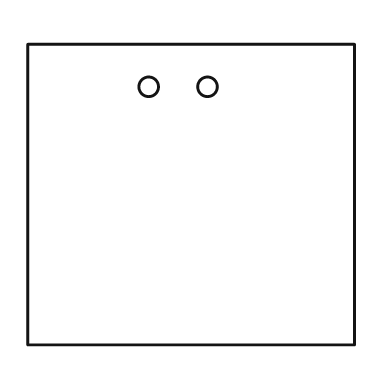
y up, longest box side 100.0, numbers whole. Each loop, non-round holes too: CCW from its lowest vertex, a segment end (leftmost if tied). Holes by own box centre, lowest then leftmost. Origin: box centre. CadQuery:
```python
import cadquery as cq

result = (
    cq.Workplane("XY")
    .moveTo(-50.0, -46.0)
    .lineTo(50.0, -46.0)
    .lineTo(50.0, 46.0)
    .lineTo(-50.0, 46.0)
    .close()
    .moveTo(-13.0, 33.0)
    .circle(3.0)
    .moveTo(5.0, 33.0)
    .circle(3.0)
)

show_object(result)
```